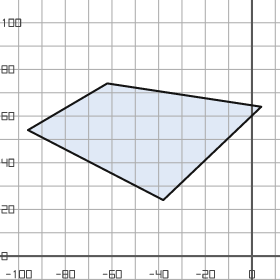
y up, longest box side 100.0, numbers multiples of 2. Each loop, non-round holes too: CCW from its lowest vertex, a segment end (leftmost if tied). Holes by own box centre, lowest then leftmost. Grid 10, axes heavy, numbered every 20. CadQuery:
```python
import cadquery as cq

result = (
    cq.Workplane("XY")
    .moveTo(-38.0, 24.0)
    .lineTo(4.0, 64.0)
    .lineTo(-62.0, 74.0)
    .lineTo(-96.0, 54.0)
    .close()
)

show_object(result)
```